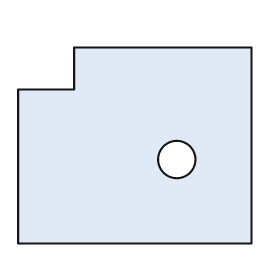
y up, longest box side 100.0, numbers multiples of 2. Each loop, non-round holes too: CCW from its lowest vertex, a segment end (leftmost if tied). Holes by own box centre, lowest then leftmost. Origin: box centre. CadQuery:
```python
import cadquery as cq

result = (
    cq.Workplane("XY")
    .moveTo(-50.0, -42.0)
    .lineTo(50.0, -42.0)
    .lineTo(50.0, 42.0)
    .lineTo(-26.0, 42.0)
    .lineTo(-26.0, 24.0)
    .lineTo(-50.0, 24.0)
    .close()
    .moveTo(18.0, -6.0)
    .circle(8.0)
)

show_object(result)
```